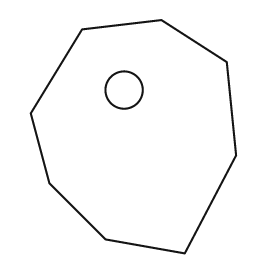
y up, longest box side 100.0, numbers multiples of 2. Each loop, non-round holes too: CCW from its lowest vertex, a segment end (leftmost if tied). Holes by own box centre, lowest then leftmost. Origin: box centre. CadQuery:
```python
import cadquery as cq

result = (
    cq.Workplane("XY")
    .moveTo(22.0, -50.0)
    .lineTo(44.0, -8.0)
    .lineTo(40.0, 32.0)
    .lineTo(12.0, 50.0)
    .lineTo(-22.0, 46.0)
    .lineTo(-44.0, 10.0)
    .lineTo(-36.0, -20.0)
    .lineTo(-12.0, -44.0)
    .close()
    .moveTo(-4.0, 20.0)
    .circle(8.0)
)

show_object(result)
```